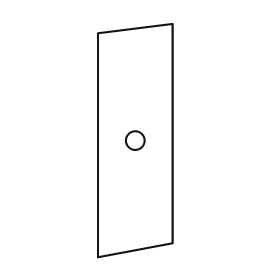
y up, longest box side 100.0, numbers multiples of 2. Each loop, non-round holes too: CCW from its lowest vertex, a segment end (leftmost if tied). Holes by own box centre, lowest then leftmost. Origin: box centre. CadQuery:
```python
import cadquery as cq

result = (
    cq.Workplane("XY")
    .moveTo(-16.0, -50.0)
    .lineTo(16.0, -44.0)
    .lineTo(16.0, 50.0)
    .lineTo(-16.0, 46.0)
    .close()
    .moveTo(0.0, 0.0)
    .circle(4.0)
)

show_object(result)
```